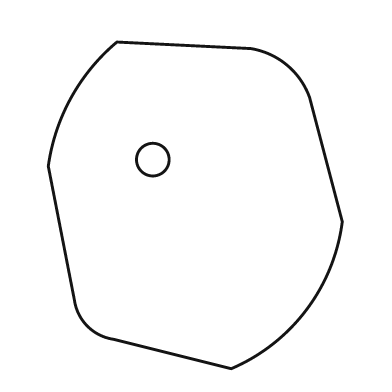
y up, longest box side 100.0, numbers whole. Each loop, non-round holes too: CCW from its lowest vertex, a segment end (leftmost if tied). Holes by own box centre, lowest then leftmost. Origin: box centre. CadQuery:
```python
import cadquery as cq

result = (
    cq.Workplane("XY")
    .moveTo(11.0, -50.0)
    .threePointArc((34.0, -32.0), (45.0, -5.0))
    .lineTo(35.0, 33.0)
    .threePointArc((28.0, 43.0), (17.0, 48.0))
    .lineTo(-24.0, 50.0)
    .threePointArc((-38.0, 33.0), (-45.0, 12.0))
    .lineTo(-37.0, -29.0)
    .threePointArc((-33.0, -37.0), (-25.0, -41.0))
    .close()
    .moveTo(-13.0, 14.0)
    .circle(5.0)
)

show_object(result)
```